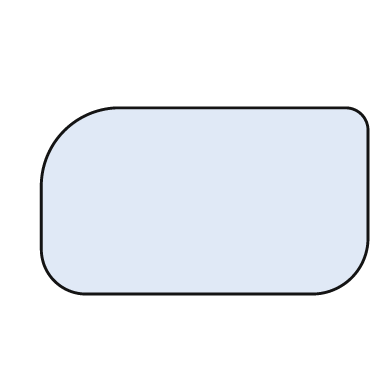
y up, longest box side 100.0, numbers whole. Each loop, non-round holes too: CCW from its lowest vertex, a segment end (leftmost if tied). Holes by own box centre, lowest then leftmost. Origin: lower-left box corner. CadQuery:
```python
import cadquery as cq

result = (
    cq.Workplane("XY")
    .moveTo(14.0, 0.0)
    .lineTo(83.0, 0.0)
    .threePointArc((95.0, 5.0), (100.0, 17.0))
    .lineTo(100.0, 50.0)
    .threePointArc((98.0, 55.0), (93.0, 57.0))
    .lineTo(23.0, 57.0)
    .threePointArc((7.0, 50.0), (0.0, 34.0))
    .lineTo(0.0, 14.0)
    .threePointArc((4.0, 4.0), (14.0, 0.0))
    .close()
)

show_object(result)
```